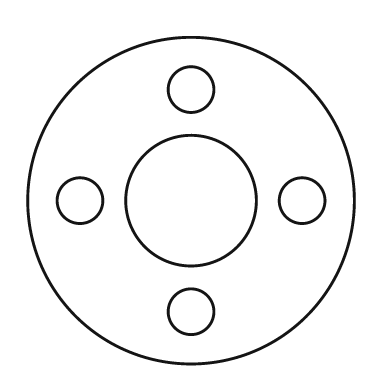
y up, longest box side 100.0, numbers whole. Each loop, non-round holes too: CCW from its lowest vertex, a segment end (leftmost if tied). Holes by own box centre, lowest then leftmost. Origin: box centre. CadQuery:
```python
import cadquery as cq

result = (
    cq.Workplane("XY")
    .moveTo(0.0, 0.0)
    .circle(50.0)
    .moveTo(0.0, -34.0)
    .circle(7.0)
    .moveTo(-34.0, 0.0)
    .circle(7.0)
    .moveTo(0.0, 0.0)
    .circle(20.0)
    .moveTo(34.0, 0.0)
    .circle(7.0)
    .moveTo(0.0, 34.0)
    .circle(7.0)
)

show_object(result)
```